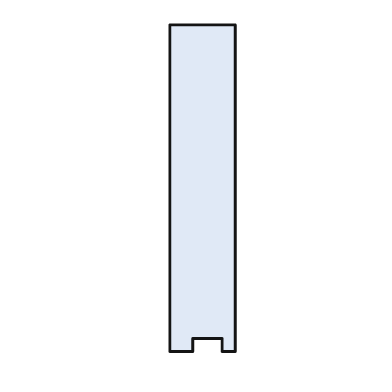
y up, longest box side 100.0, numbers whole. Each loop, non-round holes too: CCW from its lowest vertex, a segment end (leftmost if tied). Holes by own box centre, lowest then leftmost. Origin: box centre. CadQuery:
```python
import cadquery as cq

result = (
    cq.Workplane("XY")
    .moveTo(-10.0, -50.0)
    .lineTo(-3.0, -50.0)
    .lineTo(-3.0, -46.0)
    .lineTo(6.0, -46.0)
    .lineTo(6.0, -50.0)
    .lineTo(10.0, -50.0)
    .lineTo(10.0, 50.0)
    .lineTo(-10.0, 50.0)
    .close()
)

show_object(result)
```